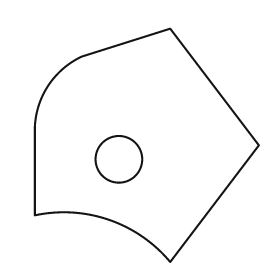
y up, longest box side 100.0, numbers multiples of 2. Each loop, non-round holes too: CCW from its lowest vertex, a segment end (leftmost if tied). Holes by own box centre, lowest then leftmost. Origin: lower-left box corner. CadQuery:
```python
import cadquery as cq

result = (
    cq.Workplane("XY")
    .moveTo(58.0, 0.0)
    .lineTo(96.0, 50.0)
    .lineTo(58.0, 100.0)
    .lineTo(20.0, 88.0)
    .threePointArc((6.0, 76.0), (0.0, 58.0))
    .lineTo(0.0, 20.0)
    .threePointArc((32.0, 18.0), (58.0, 0.0))
    .close()
    .moveTo(36.0, 44.0)
    .circle(10.0)
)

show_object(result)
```